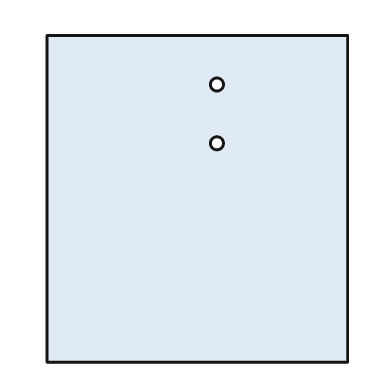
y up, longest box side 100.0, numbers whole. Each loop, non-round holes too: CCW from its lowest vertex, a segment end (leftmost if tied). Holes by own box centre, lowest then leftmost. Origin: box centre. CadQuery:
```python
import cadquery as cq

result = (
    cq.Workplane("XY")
    .moveTo(-46.0, -50.0)
    .lineTo(46.0, -50.0)
    .lineTo(46.0, 50.0)
    .lineTo(-46.0, 50.0)
    .close()
    .moveTo(6.0, 17.0)
    .circle(2.0)
    .moveTo(6.0, 35.0)
    .circle(2.0)
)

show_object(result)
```